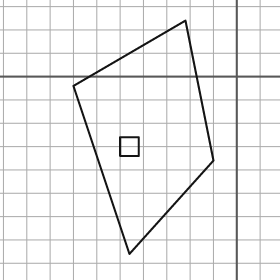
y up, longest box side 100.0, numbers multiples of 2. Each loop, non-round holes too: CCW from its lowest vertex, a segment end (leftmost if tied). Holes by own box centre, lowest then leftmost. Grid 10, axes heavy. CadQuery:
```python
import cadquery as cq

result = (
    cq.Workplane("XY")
    .moveTo(-46.0, -76.0)
    .lineTo(-10.0, -36.0)
    .lineTo(-22.0, 24.0)
    .lineTo(-70.0, -4.0)
    .close()
    .moveTo(-50.0, -34.0)
    .lineTo(-42.0, -34.0)
    .lineTo(-42.0, -26.0)
    .lineTo(-50.0, -26.0)
    .close()
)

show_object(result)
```